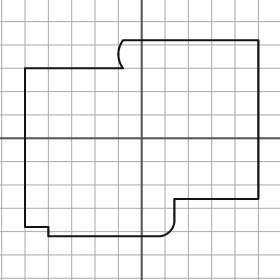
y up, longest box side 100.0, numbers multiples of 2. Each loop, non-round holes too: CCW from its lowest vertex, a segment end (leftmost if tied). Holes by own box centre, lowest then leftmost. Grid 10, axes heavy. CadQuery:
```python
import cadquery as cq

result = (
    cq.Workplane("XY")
    .moveTo(-40.0, -42.0)
    .lineTo(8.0, -42.0)
    .threePointArc((12.0, -40.0), (14.0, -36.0))
    .lineTo(14.0, -26.0)
    .lineTo(50.0, -26.0)
    .lineTo(50.0, 42.0)
    .lineTo(-8.0, 42.0)
    .threePointArc((-10.0, 36.0), (-8.0, 30.0))
    .lineTo(-50.0, 30.0)
    .lineTo(-50.0, -38.0)
    .lineTo(-40.0, -38.0)
    .close()
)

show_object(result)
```